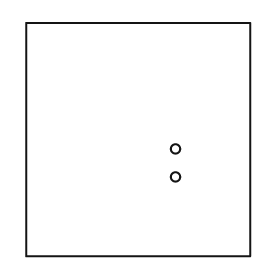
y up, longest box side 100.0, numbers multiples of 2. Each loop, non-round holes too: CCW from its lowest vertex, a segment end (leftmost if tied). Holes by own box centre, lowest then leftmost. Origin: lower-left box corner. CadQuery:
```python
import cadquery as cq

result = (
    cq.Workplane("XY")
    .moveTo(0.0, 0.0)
    .lineTo(96.0, 0.0)
    .lineTo(96.0, 100.0)
    .lineTo(0.0, 100.0)
    .close()
    .moveTo(64.0, 34.0)
    .circle(2.0)
    .moveTo(64.0, 46.0)
    .circle(2.0)
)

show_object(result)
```